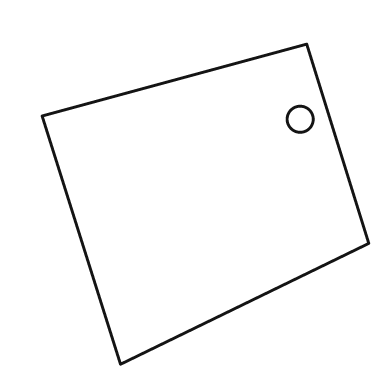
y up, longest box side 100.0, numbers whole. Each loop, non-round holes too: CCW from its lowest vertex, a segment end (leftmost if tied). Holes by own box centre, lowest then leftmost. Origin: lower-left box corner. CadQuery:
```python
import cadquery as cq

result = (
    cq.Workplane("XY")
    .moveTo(24.0, 0.0)
    .lineTo(100.0, 37.0)
    .lineTo(81.0, 98.0)
    .lineTo(0.0, 76.0)
    .close()
    .moveTo(79.0, 75.0)
    .circle(4.0)
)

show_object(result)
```